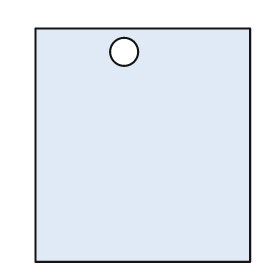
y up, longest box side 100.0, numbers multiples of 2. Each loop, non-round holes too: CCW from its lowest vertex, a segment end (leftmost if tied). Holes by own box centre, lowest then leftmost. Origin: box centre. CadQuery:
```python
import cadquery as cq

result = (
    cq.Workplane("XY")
    .moveTo(-46.0, -50.0)
    .lineTo(46.0, -50.0)
    .lineTo(46.0, 50.0)
    .lineTo(-46.0, 50.0)
    .close()
    .moveTo(-8.0, 40.0)
    .circle(6.0)
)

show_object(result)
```